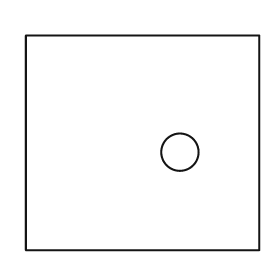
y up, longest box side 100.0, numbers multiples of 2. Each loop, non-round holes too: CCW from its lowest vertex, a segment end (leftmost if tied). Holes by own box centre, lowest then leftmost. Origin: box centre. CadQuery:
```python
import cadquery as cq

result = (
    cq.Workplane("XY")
    .moveTo(-50.0, -46.0)
    .lineTo(50.0, -46.0)
    .lineTo(50.0, 46.0)
    .lineTo(-50.0, 46.0)
    .close()
    .moveTo(16.0, -4.0)
    .circle(8.0)
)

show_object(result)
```